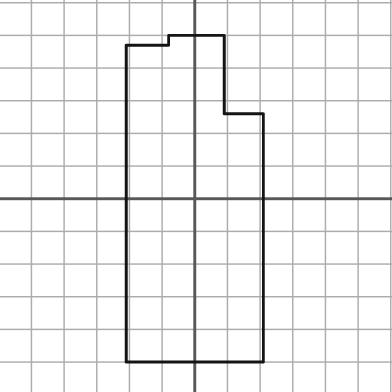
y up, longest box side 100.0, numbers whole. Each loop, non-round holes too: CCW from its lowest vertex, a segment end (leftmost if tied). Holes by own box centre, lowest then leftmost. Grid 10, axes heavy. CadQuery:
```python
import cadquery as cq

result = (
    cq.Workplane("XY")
    .moveTo(-21.0, -50.0)
    .lineTo(21.0, -50.0)
    .lineTo(21.0, 26.0)
    .lineTo(9.0, 26.0)
    .lineTo(9.0, 50.0)
    .lineTo(-8.0, 50.0)
    .lineTo(-8.0, 47.0)
    .lineTo(-21.0, 47.0)
    .close()
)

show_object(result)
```